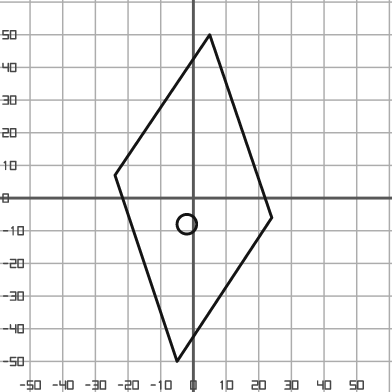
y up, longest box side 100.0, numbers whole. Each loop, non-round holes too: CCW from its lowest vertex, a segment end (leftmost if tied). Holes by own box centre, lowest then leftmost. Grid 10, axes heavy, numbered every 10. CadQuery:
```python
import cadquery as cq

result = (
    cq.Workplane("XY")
    .moveTo(-5.0, -50.0)
    .lineTo(24.0, -6.0)
    .lineTo(5.0, 50.0)
    .lineTo(-24.0, 7.0)
    .close()
    .moveTo(-2.0, -8.0)
    .circle(3.0)
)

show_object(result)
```